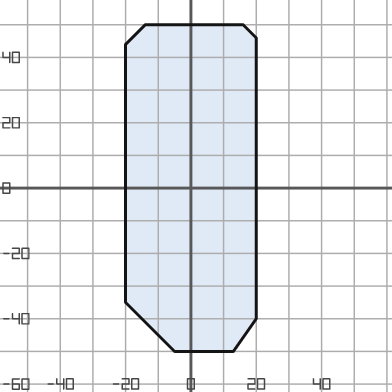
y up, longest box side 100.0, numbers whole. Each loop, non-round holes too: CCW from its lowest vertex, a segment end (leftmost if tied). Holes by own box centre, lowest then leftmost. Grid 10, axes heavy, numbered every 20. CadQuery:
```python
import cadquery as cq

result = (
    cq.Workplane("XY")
    .moveTo(-5.0, -50.0)
    .lineTo(13.0, -50.0)
    .lineTo(20.0, -40.0)
    .lineTo(20.0, 46.0)
    .lineTo(16.0, 50.0)
    .lineTo(-14.0, 50.0)
    .lineTo(-20.0, 44.0)
    .lineTo(-20.0, -35.0)
    .close()
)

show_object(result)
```